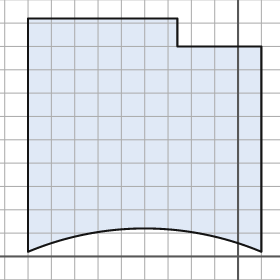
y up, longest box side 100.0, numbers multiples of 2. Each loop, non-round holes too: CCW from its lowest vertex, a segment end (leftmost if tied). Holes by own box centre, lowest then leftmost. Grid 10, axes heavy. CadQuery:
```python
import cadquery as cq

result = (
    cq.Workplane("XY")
    .moveTo(-90.0, 2.0)
    .threePointArc((-40.0, 12.0), (10.0, 2.0))
    .lineTo(10.0, 90.0)
    .lineTo(-26.0, 90.0)
    .lineTo(-26.0, 102.0)
    .lineTo(-90.0, 102.0)
    .close()
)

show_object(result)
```